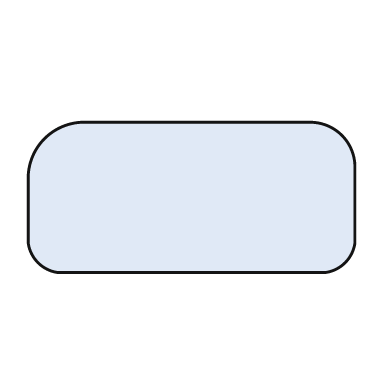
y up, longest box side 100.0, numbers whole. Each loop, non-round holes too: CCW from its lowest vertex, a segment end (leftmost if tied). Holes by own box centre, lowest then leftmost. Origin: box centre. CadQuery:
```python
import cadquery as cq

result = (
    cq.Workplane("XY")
    .moveTo(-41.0, -23.0)
    .lineTo(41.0, -23.0)
    .threePointArc((47.0, -20.0), (50.0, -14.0))
    .lineTo(50.0, 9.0)
    .threePointArc((46.0, 19.0), (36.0, 23.0))
    .lineTo(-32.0, 23.0)
    .threePointArc((-45.0, 18.0), (-50.0, 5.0))
    .lineTo(-50.0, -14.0)
    .threePointArc((-47.0, -20.0), (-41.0, -23.0))
    .close()
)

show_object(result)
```